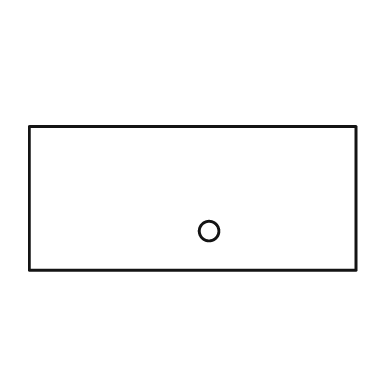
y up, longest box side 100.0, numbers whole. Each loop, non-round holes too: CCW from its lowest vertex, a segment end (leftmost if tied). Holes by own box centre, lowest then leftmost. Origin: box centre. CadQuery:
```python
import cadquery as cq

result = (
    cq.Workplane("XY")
    .moveTo(-50.0, -22.0)
    .lineTo(50.0, -22.0)
    .lineTo(50.0, 22.0)
    .lineTo(-50.0, 22.0)
    .close()
    .moveTo(5.0, -10.0)
    .circle(3.0)
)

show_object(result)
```